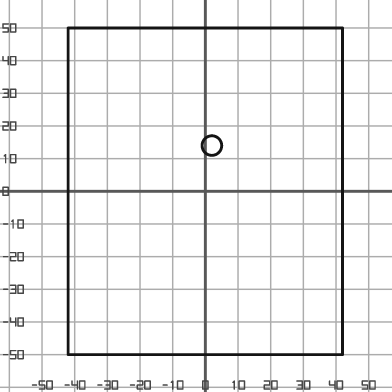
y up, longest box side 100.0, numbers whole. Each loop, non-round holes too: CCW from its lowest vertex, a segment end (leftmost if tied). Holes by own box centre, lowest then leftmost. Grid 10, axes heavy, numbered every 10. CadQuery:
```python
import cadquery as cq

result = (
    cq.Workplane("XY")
    .moveTo(-42.0, -50.0)
    .lineTo(42.0, -50.0)
    .lineTo(42.0, 50.0)
    .lineTo(-42.0, 50.0)
    .close()
    .moveTo(2.0, 14.0)
    .circle(3.0)
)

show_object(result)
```